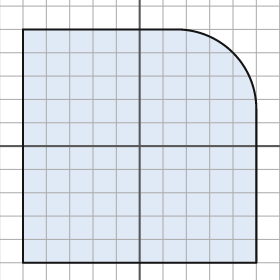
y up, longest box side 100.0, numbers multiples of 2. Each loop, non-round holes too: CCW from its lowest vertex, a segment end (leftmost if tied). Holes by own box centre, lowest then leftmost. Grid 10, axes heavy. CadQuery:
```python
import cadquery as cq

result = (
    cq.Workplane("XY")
    .moveTo(-50.0, -50.0)
    .lineTo(50.0, -50.0)
    .lineTo(50.0, 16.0)
    .threePointArc((40.0, 40.0), (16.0, 50.0))
    .lineTo(-50.0, 50.0)
    .close()
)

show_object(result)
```